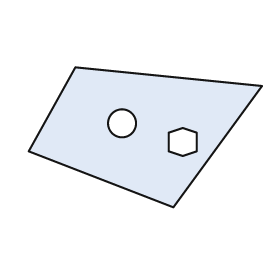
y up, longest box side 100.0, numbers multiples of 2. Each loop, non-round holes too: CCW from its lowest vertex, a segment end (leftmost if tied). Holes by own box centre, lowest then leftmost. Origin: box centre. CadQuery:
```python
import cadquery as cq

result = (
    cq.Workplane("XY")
    .moveTo(12.0, -30.0)
    .lineTo(50.0, 22.0)
    .lineTo(-30.0, 30.0)
    .lineTo(-50.0, -6.0)
    .close()
    .moveTo(16.0, -8.0)
    .lineTo(22.0, -6.0)
    .lineTo(22.0, 2.0)
    .lineTo(16.0, 4.0)
    .lineTo(10.0, 2.0)
    .lineTo(10.0, -6.0)
    .close()
    .moveTo(-10.0, 6.0)
    .circle(6.0)
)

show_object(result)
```